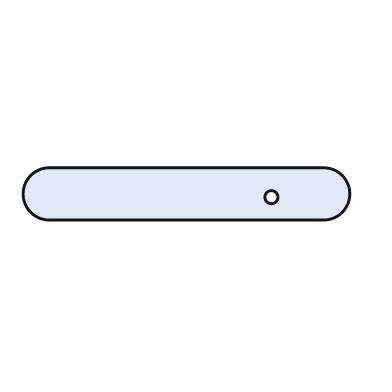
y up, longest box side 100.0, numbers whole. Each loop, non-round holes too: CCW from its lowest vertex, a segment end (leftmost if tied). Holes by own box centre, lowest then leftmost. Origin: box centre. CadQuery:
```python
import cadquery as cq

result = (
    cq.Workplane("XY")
    .moveTo(-42.0, -8.0)
    .lineTo(42.0, -8.0)
    .threePointArc((50.0, 0.0), (42.0, 8.0))
    .lineTo(-42.0, 8.0)
    .threePointArc((-50.0, 0.0), (-42.0, -8.0))
    .close()
    .moveTo(26.0, -1.0)
    .circle(2.0)
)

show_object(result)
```